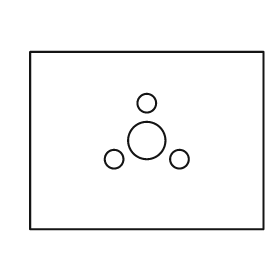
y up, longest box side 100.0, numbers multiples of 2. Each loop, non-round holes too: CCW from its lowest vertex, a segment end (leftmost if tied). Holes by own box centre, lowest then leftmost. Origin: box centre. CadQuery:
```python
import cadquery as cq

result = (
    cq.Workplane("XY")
    .moveTo(-50.0, -38.0)
    .lineTo(50.0, -38.0)
    .lineTo(50.0, 38.0)
    .lineTo(-50.0, 38.0)
    .close()
    .moveTo(-14.0, -8.0)
    .circle(4.0)
    .moveTo(14.0, -8.0)
    .circle(4.0)
    .moveTo(0.0, 0.0)
    .circle(8.0)
    .moveTo(0.0, 16.0)
    .circle(4.0)
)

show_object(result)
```